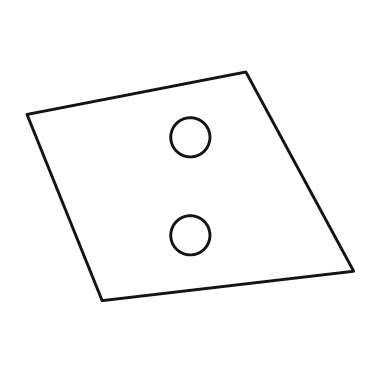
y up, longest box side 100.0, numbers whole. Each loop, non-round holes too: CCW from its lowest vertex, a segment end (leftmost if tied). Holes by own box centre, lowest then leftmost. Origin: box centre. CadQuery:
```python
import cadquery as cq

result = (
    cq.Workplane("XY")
    .moveTo(-27.0, -35.0)
    .lineTo(50.0, -26.0)
    .lineTo(17.0, 35.0)
    .lineTo(-50.0, 22.0)
    .close()
    .moveTo(0.0, -15.0)
    .circle(6.0)
    .moveTo(0.0, 15.0)
    .circle(6.0)
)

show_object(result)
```